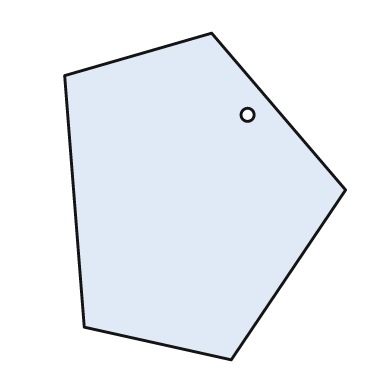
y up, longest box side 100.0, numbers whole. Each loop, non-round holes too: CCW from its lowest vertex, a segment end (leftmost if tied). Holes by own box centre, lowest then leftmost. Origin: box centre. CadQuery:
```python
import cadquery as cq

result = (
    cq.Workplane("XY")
    .moveTo(8.0, -50.0)
    .lineTo(43.0, 2.0)
    .lineTo(2.0, 50.0)
    .lineTo(-43.0, 37.0)
    .lineTo(-37.0, -40.0)
    .close()
    .moveTo(13.0, 25.0)
    .circle(2.0)
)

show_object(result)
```